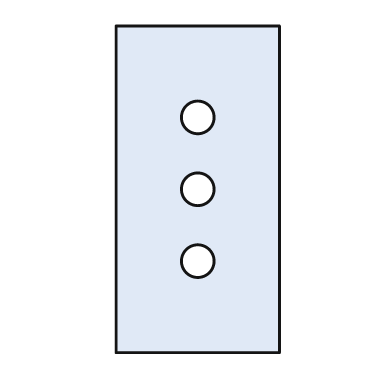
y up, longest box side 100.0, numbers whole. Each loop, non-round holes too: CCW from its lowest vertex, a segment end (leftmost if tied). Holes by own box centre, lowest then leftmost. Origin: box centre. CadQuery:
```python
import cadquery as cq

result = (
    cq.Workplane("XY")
    .moveTo(-25.0, -50.0)
    .lineTo(25.0, -50.0)
    .lineTo(25.0, 50.0)
    .lineTo(-25.0, 50.0)
    .close()
    .moveTo(0.0, -22.0)
    .circle(5.0)
    .moveTo(0.0, 0.0)
    .circle(5.0)
    .moveTo(0.0, 22.0)
    .circle(5.0)
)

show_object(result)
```